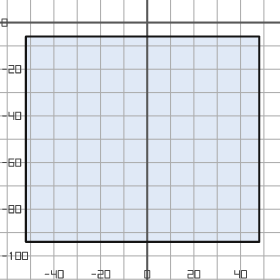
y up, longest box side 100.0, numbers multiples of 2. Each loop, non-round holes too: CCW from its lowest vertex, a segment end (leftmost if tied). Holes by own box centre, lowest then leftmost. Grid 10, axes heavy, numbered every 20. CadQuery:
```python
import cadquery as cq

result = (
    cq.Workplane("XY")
    .moveTo(-52.0, -94.0)
    .lineTo(48.0, -94.0)
    .lineTo(48.0, -6.0)
    .lineTo(-52.0, -6.0)
    .close()
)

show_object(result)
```